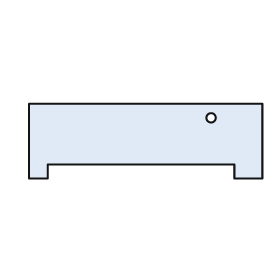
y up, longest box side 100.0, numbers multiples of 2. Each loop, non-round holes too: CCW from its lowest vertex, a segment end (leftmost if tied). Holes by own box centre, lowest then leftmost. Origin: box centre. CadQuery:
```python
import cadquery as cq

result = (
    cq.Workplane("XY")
    .moveTo(-50.0, -16.0)
    .lineTo(-42.0, -16.0)
    .lineTo(-42.0, -10.0)
    .lineTo(38.0, -10.0)
    .lineTo(38.0, -16.0)
    .lineTo(50.0, -16.0)
    .lineTo(50.0, 16.0)
    .lineTo(-50.0, 16.0)
    .close()
    .moveTo(28.0, 10.0)
    .circle(2.0)
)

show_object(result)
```